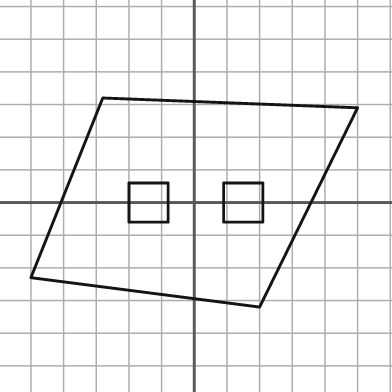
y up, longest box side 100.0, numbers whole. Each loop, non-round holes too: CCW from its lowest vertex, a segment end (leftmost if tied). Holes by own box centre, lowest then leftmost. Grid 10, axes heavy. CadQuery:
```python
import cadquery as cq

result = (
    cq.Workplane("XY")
    .moveTo(20.0, -32.0)
    .lineTo(50.0, 29.0)
    .lineTo(-28.0, 32.0)
    .lineTo(-50.0, -23.0)
    .close()
    .moveTo(-20.0, -6.0)
    .lineTo(-8.0, -6.0)
    .lineTo(-8.0, 6.0)
    .lineTo(-20.0, 6.0)
    .close()
    .moveTo(9.0, -6.0)
    .lineTo(21.0, -6.0)
    .lineTo(21.0, 6.0)
    .lineTo(9.0, 6.0)
    .close()
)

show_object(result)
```